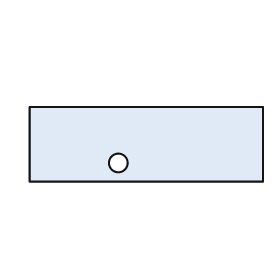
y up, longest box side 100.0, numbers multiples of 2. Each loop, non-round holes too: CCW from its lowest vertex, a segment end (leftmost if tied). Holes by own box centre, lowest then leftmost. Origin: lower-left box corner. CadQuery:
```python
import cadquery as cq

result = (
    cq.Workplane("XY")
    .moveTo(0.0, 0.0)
    .lineTo(100.0, 0.0)
    .lineTo(100.0, 32.0)
    .lineTo(0.0, 32.0)
    .close()
    .moveTo(38.0, 8.0)
    .circle(4.0)
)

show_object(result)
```